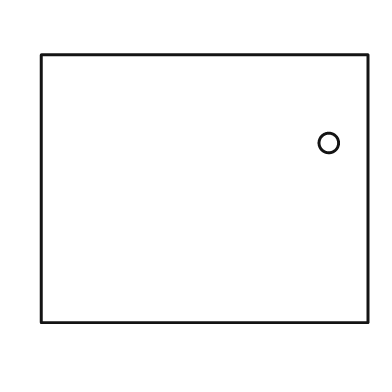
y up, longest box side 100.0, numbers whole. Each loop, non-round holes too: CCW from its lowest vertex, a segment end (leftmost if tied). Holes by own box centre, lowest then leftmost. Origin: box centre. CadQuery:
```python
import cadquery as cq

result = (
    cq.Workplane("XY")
    .moveTo(-50.0, -41.0)
    .lineTo(50.0, -41.0)
    .lineTo(50.0, 41.0)
    .lineTo(-50.0, 41.0)
    .close()
    .moveTo(38.0, 14.0)
    .circle(3.0)
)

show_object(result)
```